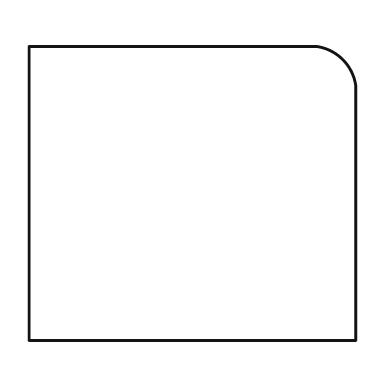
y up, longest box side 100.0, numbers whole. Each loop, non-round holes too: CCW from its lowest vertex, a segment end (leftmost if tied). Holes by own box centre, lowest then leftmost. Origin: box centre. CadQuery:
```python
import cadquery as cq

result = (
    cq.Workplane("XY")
    .moveTo(-50.0, -45.0)
    .lineTo(50.0, -45.0)
    .lineTo(50.0, 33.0)
    .threePointArc((46.0, 41.0), (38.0, 45.0))
    .lineTo(-50.0, 45.0)
    .close()
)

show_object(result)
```